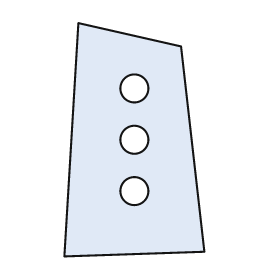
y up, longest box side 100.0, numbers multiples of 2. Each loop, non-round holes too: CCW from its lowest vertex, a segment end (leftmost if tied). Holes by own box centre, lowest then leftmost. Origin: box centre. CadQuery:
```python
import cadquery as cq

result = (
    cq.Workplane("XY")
    .moveTo(-30.0, -50.0)
    .lineTo(30.0, -48.0)
    .lineTo(20.0, 40.0)
    .lineTo(-24.0, 50.0)
    .close()
    .moveTo(0.0, -22.0)
    .circle(6.0)
    .moveTo(0.0, 0.0)
    .circle(6.0)
    .moveTo(0.0, 22.0)
    .circle(6.0)
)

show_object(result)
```